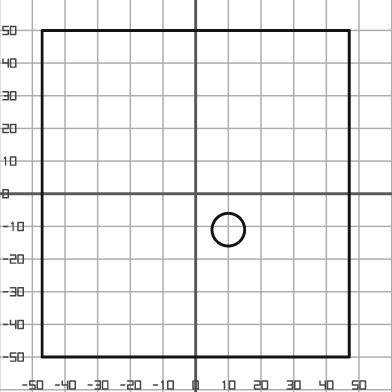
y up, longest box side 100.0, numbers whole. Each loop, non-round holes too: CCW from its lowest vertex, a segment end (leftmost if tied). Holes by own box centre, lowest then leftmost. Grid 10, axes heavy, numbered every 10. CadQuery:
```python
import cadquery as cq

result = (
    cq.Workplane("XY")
    .moveTo(-47.0, -50.0)
    .lineTo(47.0, -50.0)
    .lineTo(47.0, 50.0)
    .lineTo(-47.0, 50.0)
    .close()
    .moveTo(10.0, -11.0)
    .circle(5.0)
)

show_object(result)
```